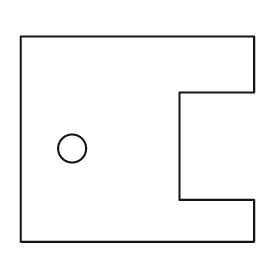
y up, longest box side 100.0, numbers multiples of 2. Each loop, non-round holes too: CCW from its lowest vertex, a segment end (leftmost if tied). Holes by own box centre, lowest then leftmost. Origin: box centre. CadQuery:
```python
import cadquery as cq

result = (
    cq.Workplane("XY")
    .moveTo(-50.0, -44.0)
    .lineTo(50.0, -44.0)
    .lineTo(50.0, -26.0)
    .lineTo(18.0, -26.0)
    .lineTo(18.0, 20.0)
    .lineTo(50.0, 20.0)
    .lineTo(50.0, 44.0)
    .lineTo(-50.0, 44.0)
    .close()
    .moveTo(-28.0, -4.0)
    .circle(6.0)
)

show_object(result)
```